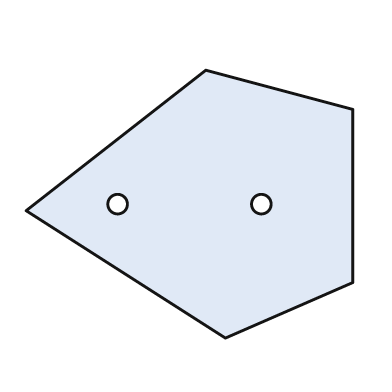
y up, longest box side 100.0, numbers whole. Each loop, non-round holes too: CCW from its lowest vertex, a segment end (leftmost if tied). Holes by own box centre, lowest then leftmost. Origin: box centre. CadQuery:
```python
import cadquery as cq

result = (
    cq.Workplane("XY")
    .moveTo(11.0, -41.0)
    .lineTo(50.0, -24.0)
    .lineTo(50.0, 29.0)
    .lineTo(5.0, 41.0)
    .lineTo(-50.0, -2.0)
    .close()
    .moveTo(-22.0, 0.0)
    .circle(3.0)
    .moveTo(22.0, 0.0)
    .circle(3.0)
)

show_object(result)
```